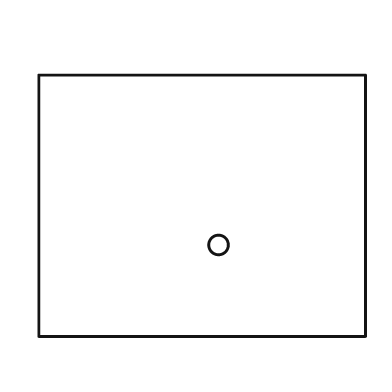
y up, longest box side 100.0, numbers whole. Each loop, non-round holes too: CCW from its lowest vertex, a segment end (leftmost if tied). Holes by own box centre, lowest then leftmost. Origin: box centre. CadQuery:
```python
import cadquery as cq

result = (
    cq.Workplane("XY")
    .moveTo(-50.0, -40.0)
    .lineTo(50.0, -40.0)
    .lineTo(50.0, 40.0)
    .lineTo(-50.0, 40.0)
    .close()
    .moveTo(5.0, -12.0)
    .circle(3.0)
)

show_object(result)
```